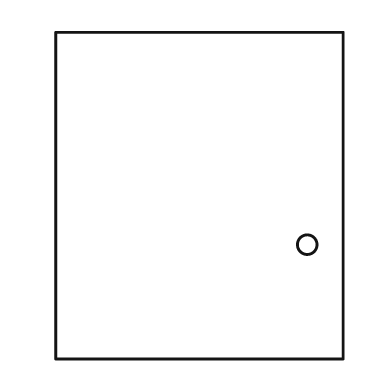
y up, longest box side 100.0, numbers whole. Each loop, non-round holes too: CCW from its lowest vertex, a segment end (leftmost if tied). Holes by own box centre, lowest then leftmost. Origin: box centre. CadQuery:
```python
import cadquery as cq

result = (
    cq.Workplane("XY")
    .moveTo(-44.0, -50.0)
    .lineTo(44.0, -50.0)
    .lineTo(44.0, 50.0)
    .lineTo(-44.0, 50.0)
    .close()
    .moveTo(33.0, -15.0)
    .circle(3.0)
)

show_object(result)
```